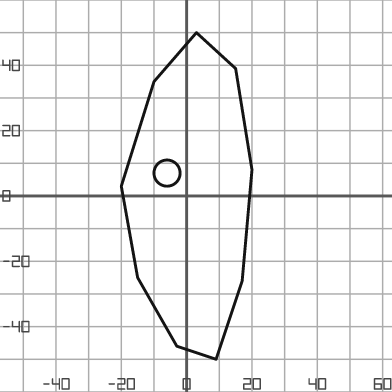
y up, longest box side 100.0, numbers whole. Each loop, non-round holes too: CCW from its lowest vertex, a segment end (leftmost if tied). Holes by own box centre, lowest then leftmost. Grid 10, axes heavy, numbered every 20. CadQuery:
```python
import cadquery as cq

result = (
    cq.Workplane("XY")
    .moveTo(9.0, -50.0)
    .lineTo(17.0, -26.0)
    .lineTo(20.0, 8.0)
    .lineTo(15.0, 39.0)
    .lineTo(3.0, 50.0)
    .lineTo(-10.0, 35.0)
    .lineTo(-20.0, 3.0)
    .lineTo(-15.0, -25.0)
    .lineTo(-3.0, -46.0)
    .close()
    .moveTo(-6.0, 7.0)
    .circle(4.0)
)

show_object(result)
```